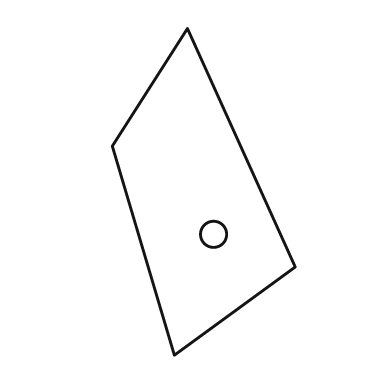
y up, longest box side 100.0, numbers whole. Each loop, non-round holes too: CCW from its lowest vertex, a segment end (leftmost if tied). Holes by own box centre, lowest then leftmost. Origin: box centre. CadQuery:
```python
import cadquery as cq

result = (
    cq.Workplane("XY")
    .moveTo(-9.0, -50.0)
    .lineTo(28.0, -23.0)
    .lineTo(-5.0, 50.0)
    .lineTo(-28.0, 14.0)
    .close()
    .moveTo(3.0, -13.0)
    .circle(4.0)
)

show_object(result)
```